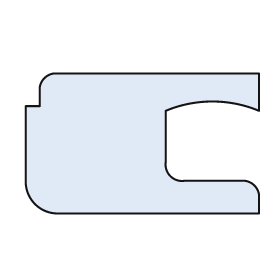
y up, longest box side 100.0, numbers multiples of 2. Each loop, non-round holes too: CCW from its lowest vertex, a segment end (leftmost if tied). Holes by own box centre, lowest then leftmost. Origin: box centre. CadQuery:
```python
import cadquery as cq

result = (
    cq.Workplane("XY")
    .moveTo(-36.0, -30.0)
    .lineTo(50.0, -30.0)
    .lineTo(50.0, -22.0)
    .threePointArc((48.0, -18.0), (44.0, -16.0))
    .lineTo(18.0, -16.0)
    .threePointArc((12.0, -14.0), (10.0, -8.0))
    .lineTo(10.0, 14.0)
    .threePointArc((30.0, 18.0), (50.0, 14.0))
    .lineTo(50.0, 30.0)
    .lineTo(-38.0, 30.0)
    .threePointArc((-42.0, 28.0), (-44.0, 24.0))
    .lineTo(-44.0, 16.0)
    .lineTo(-50.0, 16.0)
    .lineTo(-50.0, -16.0)
    .threePointArc((-46.0, -26.0), (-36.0, -30.0))
    .close()
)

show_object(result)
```